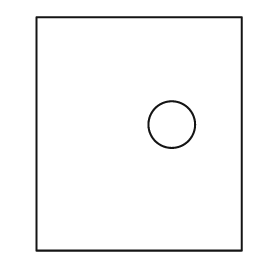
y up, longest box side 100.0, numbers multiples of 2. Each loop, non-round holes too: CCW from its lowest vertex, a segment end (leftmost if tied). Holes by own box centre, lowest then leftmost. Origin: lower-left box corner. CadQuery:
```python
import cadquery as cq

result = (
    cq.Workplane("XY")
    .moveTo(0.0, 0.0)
    .lineTo(88.0, 0.0)
    .lineTo(88.0, 100.0)
    .lineTo(0.0, 100.0)
    .close()
    .moveTo(58.0, 54.0)
    .circle(10.0)
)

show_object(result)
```